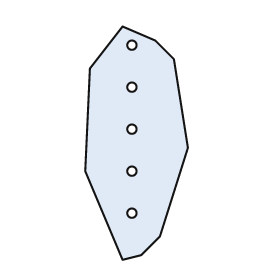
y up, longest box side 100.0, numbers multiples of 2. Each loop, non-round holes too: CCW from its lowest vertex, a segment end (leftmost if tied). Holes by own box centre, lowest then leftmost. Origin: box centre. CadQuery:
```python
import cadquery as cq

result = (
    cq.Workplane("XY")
    .moveTo(-6.0, -50.0)
    .lineTo(2.0, -48.0)
    .lineTo(10.0, -40.0)
    .lineTo(22.0, -2.0)
    .lineTo(16.0, 36.0)
    .lineTo(8.0, 44.0)
    .lineTo(-6.0, 50.0)
    .lineTo(-20.0, 32.0)
    .lineTo(-22.0, -12.0)
    .close()
    .moveTo(-2.0, -30.0)
    .circle(2.0)
    .moveTo(-2.0, -12.0)
    .circle(2.0)
    .moveTo(-2.0, 6.0)
    .circle(2.0)
    .moveTo(-2.0, 24.0)
    .circle(2.0)
    .moveTo(-2.0, 42.0)
    .circle(2.0)
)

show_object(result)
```